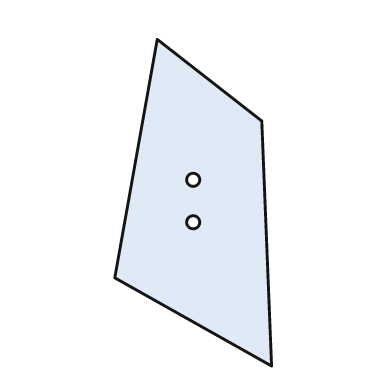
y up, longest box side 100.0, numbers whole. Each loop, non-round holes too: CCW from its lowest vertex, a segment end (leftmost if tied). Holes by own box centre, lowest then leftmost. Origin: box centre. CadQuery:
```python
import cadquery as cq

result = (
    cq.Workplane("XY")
    .moveTo(24.0, -50.0)
    .lineTo(21.0, 25.0)
    .lineTo(-11.0, 50.0)
    .lineTo(-24.0, -23.0)
    .close()
    .moveTo(0.0, -6.0)
    .circle(2.0)
    .moveTo(0.0, 7.0)
    .circle(2.0)
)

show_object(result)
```